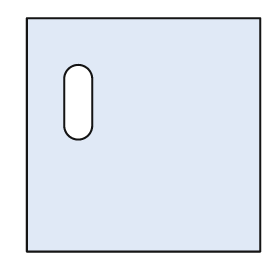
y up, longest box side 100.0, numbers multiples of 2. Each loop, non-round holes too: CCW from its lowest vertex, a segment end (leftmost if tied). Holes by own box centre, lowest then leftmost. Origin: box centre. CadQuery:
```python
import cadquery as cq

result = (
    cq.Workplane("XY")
    .moveTo(-50.0, -50.0)
    .lineTo(50.0, -50.0)
    .lineTo(50.0, 50.0)
    .lineTo(-50.0, 50.0)
    .close()
    .moveTo(-34.0, 4.0)
    .threePointArc((-28.0, -2.0), (-22.0, 4.0))
    .lineTo(-22.0, 24.0)
    .threePointArc((-28.0, 30.0), (-34.0, 24.0))
    .close()
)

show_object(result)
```